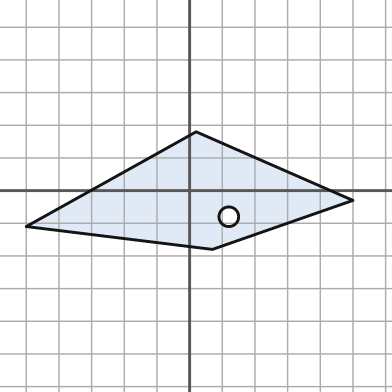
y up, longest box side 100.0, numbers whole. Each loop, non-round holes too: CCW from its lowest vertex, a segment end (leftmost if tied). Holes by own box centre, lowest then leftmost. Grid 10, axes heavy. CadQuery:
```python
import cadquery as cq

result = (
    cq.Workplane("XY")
    .moveTo(7.0, -18.0)
    .lineTo(50.0, -3.0)
    .lineTo(2.0, 18.0)
    .lineTo(-50.0, -11.0)
    .close()
    .moveTo(12.0, -8.0)
    .circle(3.0)
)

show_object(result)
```